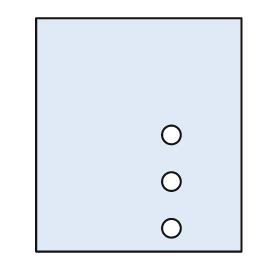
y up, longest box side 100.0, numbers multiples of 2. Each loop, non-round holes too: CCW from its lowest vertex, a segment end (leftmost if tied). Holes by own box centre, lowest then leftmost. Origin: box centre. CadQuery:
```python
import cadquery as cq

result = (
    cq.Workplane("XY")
    .moveTo(-44.0, -50.0)
    .lineTo(44.0, -50.0)
    .lineTo(44.0, 50.0)
    .lineTo(-44.0, 50.0)
    .close()
    .moveTo(14.0, -40.0)
    .circle(4.0)
    .moveTo(14.0, -20.0)
    .circle(4.0)
    .moveTo(14.0, 0.0)
    .circle(4.0)
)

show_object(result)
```